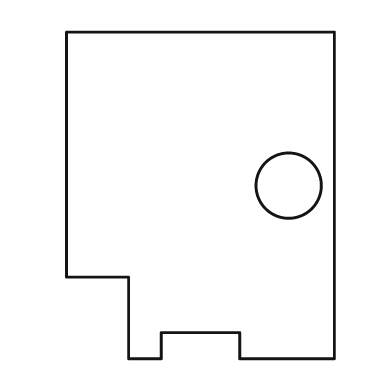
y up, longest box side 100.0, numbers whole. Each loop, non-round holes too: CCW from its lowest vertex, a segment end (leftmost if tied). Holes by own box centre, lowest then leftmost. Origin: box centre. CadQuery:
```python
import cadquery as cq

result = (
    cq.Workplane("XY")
    .moveTo(-22.0, -50.0)
    .lineTo(-12.0, -50.0)
    .lineTo(-12.0, -42.0)
    .lineTo(12.0, -42.0)
    .lineTo(12.0, -50.0)
    .lineTo(41.0, -50.0)
    .lineTo(41.0, 50.0)
    .lineTo(-41.0, 50.0)
    .lineTo(-41.0, -25.0)
    .lineTo(-22.0, -25.0)
    .close()
    .moveTo(27.0, 3.0)
    .circle(10.0)
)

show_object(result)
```